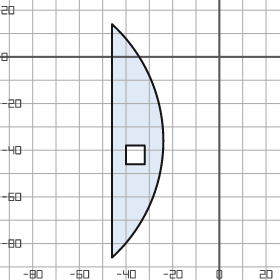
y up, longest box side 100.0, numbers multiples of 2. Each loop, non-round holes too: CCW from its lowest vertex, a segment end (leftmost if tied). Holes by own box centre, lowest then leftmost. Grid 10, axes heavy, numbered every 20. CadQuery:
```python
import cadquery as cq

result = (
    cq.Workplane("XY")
    .moveTo(-46.0, -86.0)
    .threePointArc((-24.0, -36.0), (-46.0, 14.0))
    .close()
    .moveTo(-40.0, -46.0)
    .lineTo(-32.0, -46.0)
    .lineTo(-32.0, -38.0)
    .lineTo(-40.0, -38.0)
    .close()
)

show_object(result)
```